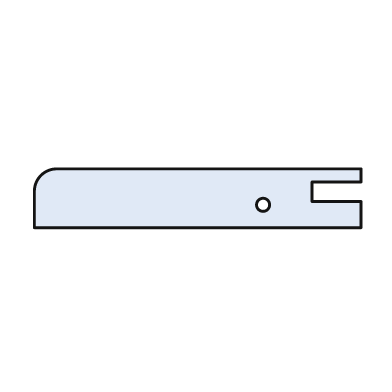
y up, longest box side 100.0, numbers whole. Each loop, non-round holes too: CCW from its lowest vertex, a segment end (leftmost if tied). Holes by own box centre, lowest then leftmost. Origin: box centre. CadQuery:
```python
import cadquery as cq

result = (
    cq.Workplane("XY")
    .moveTo(-50.0, -9.0)
    .lineTo(50.0, -9.0)
    .lineTo(50.0, -1.0)
    .lineTo(35.0, -1.0)
    .lineTo(35.0, 5.0)
    .lineTo(50.0, 5.0)
    .lineTo(50.0, 9.0)
    .lineTo(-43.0, 9.0)
    .threePointArc((-48.0, 7.0), (-50.0, 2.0))
    .close()
    .moveTo(20.0, -2.0)
    .circle(2.0)
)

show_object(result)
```